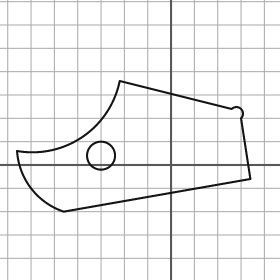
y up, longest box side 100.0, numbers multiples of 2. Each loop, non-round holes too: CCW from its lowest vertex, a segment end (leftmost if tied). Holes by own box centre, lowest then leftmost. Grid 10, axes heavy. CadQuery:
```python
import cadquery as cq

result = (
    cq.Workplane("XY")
    .moveTo(-46.0, -20.0)
    .lineTo(34.0, -6.0)
    .lineTo(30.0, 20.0)
    .threePointArc((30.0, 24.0), (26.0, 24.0))
    .lineTo(-22.0, 36.0)
    .threePointArc((-38.0, 12.0), (-66.0, 6.0))
    .threePointArc((-60.0, -10.0), (-46.0, -20.0))
    .close()
    .moveTo(-30.0, 4.0)
    .circle(6.0)
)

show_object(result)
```